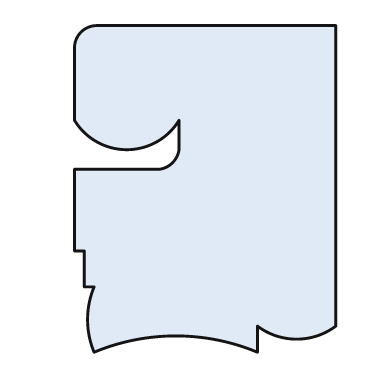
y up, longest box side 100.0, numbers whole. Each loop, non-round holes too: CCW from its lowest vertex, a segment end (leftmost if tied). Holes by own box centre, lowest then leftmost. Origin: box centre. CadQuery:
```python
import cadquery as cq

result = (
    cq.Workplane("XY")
    .moveTo(-34.0, -50.0)
    .threePointArc((-9.0, -45.0), (16.0, -50.0))
    .lineTo(16.0, -42.0)
    .threePointArc((28.0, -46.0), (40.0, -42.0))
    .lineTo(40.0, 50.0)
    .lineTo(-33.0, 50.0)
    .threePointArc((-38.0, 48.0), (-40.0, 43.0))
    .lineTo(-40.0, 21.0)
    .threePointArc((-24.0, 12.0), (-8.0, 21.0))
    .lineTo(-8.0, 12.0)
    .threePointArc((-10.0, 8.0), (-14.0, 6.0))
    .lineTo(-40.0, 6.0)
    .lineTo(-40.0, -19.0)
    .lineTo(-37.0, -19.0)
    .lineTo(-37.0, -30.0)
    .lineTo(-34.0, -30.0)
    .threePointArc((-36.0, -40.0), (-34.0, -50.0))
    .close()
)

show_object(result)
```